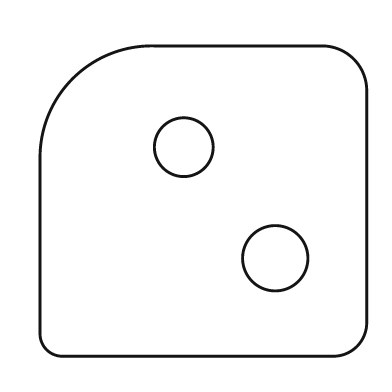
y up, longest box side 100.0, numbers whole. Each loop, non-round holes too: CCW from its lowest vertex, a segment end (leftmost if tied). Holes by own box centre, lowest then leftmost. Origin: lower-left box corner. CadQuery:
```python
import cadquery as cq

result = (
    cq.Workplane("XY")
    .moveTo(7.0, 0.0)
    .lineTo(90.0, 0.0)
    .threePointArc((97.0, 3.0), (100.0, 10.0))
    .lineTo(100.0, 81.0)
    .threePointArc((96.0, 91.0), (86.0, 95.0))
    .lineTo(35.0, 95.0)
    .threePointArc((10.0, 85.0), (0.0, 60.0))
    .lineTo(0.0, 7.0)
    .threePointArc((2.0, 2.0), (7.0, 0.0))
    .close()
    .moveTo(72.0, 30.0)
    .circle(10.0)
    .moveTo(44.0, 64.0)
    .circle(9.0)
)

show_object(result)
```